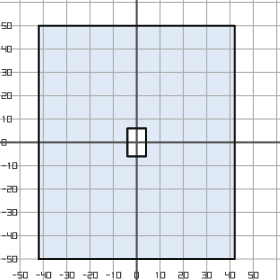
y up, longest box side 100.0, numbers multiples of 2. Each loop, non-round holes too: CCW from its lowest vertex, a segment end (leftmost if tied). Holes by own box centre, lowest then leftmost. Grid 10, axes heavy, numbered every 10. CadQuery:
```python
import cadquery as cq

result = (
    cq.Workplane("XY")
    .moveTo(-42.0, -50.0)
    .lineTo(42.0, -50.0)
    .lineTo(42.0, 50.0)
    .lineTo(-42.0, 50.0)
    .close()
    .moveTo(-4.0, -6.0)
    .lineTo(4.0, -6.0)
    .lineTo(4.0, 6.0)
    .lineTo(-4.0, 6.0)
    .close()
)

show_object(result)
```